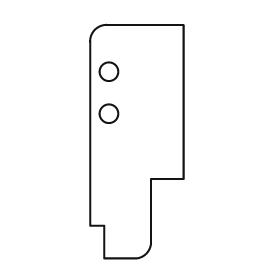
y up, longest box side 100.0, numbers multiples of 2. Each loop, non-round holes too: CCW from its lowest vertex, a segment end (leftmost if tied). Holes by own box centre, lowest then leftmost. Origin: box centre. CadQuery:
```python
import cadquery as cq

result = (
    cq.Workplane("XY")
    .moveTo(-14.0, -50.0)
    .lineTo(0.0, -50.0)
    .threePointArc((4.0, -48.0), (6.0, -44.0))
    .lineTo(6.0, -16.0)
    .lineTo(20.0, -16.0)
    .lineTo(20.0, 50.0)
    .lineTo(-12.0, 50.0)
    .threePointArc((-18.0, 48.0), (-20.0, 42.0))
    .lineTo(-20.0, -36.0)
    .lineTo(-14.0, -36.0)
    .close()
    .moveTo(-12.0, 12.0)
    .circle(4.0)
    .moveTo(-12.0, 30.0)
    .circle(4.0)
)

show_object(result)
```